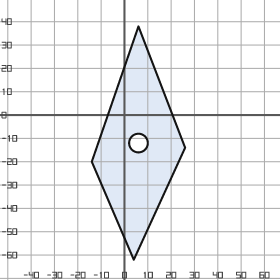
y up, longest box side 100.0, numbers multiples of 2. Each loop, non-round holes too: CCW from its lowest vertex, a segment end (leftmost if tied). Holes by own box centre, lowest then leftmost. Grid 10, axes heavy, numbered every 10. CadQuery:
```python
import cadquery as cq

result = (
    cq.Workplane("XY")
    .moveTo(4.0, -62.0)
    .lineTo(26.0, -14.0)
    .lineTo(6.0, 38.0)
    .lineTo(-14.0, -20.0)
    .close()
    .moveTo(6.0, -12.0)
    .circle(4.0)
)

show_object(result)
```